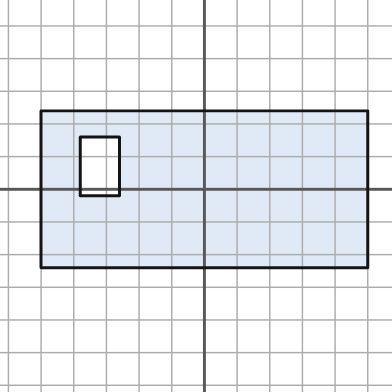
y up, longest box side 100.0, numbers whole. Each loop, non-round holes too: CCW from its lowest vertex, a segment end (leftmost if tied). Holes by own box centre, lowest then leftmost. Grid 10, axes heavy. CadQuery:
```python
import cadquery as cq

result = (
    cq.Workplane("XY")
    .moveTo(-50.0, -24.0)
    .lineTo(50.0, -24.0)
    .lineTo(50.0, 24.0)
    .lineTo(-50.0, 24.0)
    .close()
    .moveTo(-38.0, -2.0)
    .lineTo(-26.0, -2.0)
    .lineTo(-26.0, 16.0)
    .lineTo(-38.0, 16.0)
    .close()
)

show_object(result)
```